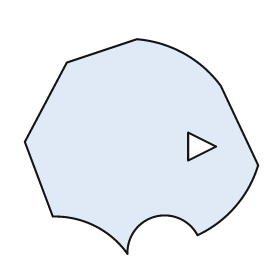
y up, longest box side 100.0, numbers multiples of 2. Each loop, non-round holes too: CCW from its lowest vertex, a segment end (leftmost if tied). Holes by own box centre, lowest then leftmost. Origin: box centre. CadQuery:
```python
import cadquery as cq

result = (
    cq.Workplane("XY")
    .moveTo(-6.0, -46.0)
    .threePointArc((6.0, -30.0), (24.0, -38.0))
    .threePointArc((40.0, -26.0), (50.0, -8.0))
    .lineTo(34.0, 26.0)
    .threePointArc((18.0, 40.0), (-2.0, 46.0))
    .lineTo(-32.0, 36.0)
    .lineTo(-50.0, 2.0)
    .lineTo(-38.0, -30.0)
    .threePointArc((-20.0, -34.0), (-6.0, -46.0))
    .close()
    .moveTo(20.0, -6.0)
    .lineTo(32.0, 0.0)
    .lineTo(20.0, 6.0)
    .close()
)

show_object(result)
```